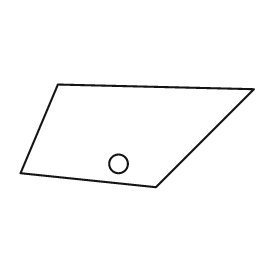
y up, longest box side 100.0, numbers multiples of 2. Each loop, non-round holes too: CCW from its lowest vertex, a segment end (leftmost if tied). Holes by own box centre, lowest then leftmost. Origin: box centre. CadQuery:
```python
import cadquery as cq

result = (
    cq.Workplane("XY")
    .moveTo(8.0, -22.0)
    .lineTo(50.0, 20.0)
    .lineTo(-34.0, 22.0)
    .lineTo(-50.0, -16.0)
    .close()
    .moveTo(-8.0, -12.0)
    .circle(4.0)
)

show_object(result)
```